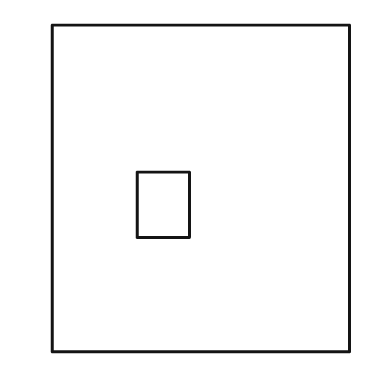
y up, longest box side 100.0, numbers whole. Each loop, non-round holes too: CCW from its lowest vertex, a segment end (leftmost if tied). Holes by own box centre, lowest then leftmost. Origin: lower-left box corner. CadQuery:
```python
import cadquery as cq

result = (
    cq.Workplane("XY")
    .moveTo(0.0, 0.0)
    .lineTo(91.0, 0.0)
    .lineTo(91.0, 100.0)
    .lineTo(0.0, 100.0)
    .close()
    .moveTo(26.0, 35.0)
    .lineTo(42.0, 35.0)
    .lineTo(42.0, 55.0)
    .lineTo(26.0, 55.0)
    .close()
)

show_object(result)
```